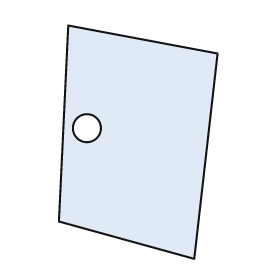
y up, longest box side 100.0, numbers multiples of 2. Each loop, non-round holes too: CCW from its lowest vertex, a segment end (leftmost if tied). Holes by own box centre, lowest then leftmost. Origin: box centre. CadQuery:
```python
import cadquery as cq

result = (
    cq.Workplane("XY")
    .moveTo(24.0, -50.0)
    .lineTo(34.0, 38.0)
    .lineTo(-30.0, 50.0)
    .lineTo(-34.0, -34.0)
    .close()
    .moveTo(-22.0, 6.0)
    .circle(6.0)
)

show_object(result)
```